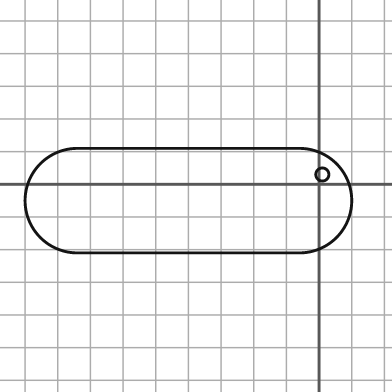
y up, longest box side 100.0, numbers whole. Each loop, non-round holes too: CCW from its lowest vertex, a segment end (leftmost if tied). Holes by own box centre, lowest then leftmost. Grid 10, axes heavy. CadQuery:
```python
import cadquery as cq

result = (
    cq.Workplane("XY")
    .moveTo(-74.0, -21.0)
    .lineTo(-6.0, -21.0)
    .threePointArc((10.0, -5.0), (-6.0, 11.0))
    .lineTo(-74.0, 11.0)
    .threePointArc((-90.0, -5.0), (-74.0, -21.0))
    .close()
    .moveTo(1.0, 3.0)
    .circle(2.0)
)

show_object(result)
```